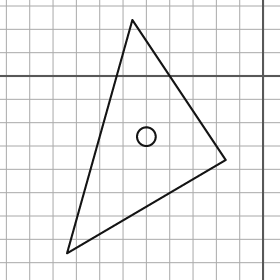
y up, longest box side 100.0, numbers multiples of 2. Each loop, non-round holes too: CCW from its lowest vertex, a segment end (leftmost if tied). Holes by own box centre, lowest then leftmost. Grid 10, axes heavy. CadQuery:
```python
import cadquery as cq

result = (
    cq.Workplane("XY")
    .moveTo(-84.0, -76.0)
    .lineTo(-16.0, -36.0)
    .lineTo(-56.0, 24.0)
    .close()
    .moveTo(-50.0, -26.0)
    .circle(4.0)
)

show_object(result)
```